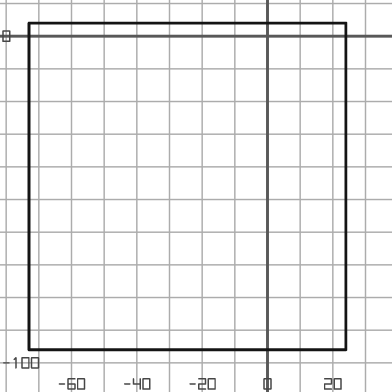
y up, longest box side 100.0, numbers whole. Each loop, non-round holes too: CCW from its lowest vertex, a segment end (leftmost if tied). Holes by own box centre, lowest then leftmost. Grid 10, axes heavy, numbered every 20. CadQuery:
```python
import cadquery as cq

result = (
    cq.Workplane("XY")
    .moveTo(-73.0, -96.0)
    .lineTo(24.0, -96.0)
    .lineTo(24.0, 4.0)
    .lineTo(-73.0, 4.0)
    .close()
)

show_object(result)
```